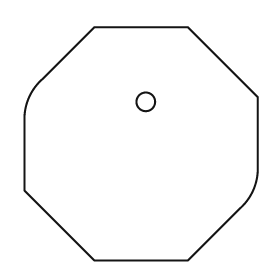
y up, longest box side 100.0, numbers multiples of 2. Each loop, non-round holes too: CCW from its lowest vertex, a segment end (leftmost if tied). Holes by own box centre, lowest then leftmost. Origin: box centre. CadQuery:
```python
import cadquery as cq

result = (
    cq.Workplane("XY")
    .moveTo(-20.0, -50.0)
    .lineTo(20.0, -50.0)
    .lineTo(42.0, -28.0)
    .threePointArc((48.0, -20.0), (50.0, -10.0))
    .lineTo(50.0, 20.0)
    .lineTo(20.0, 50.0)
    .lineTo(-20.0, 50.0)
    .lineTo(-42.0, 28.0)
    .threePointArc((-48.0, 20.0), (-50.0, 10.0))
    .lineTo(-50.0, -20.0)
    .close()
    .moveTo(2.0, 18.0)
    .circle(4.0)
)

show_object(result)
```